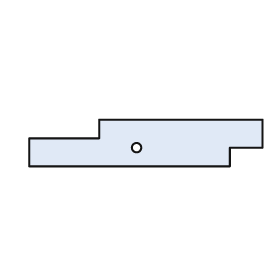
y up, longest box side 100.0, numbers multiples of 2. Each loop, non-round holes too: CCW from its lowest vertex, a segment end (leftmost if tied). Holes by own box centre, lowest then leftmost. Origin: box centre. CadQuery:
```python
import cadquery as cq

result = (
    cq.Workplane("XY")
    .moveTo(-50.0, -10.0)
    .lineTo(36.0, -10.0)
    .lineTo(36.0, -2.0)
    .lineTo(50.0, -2.0)
    .lineTo(50.0, 10.0)
    .lineTo(-20.0, 10.0)
    .lineTo(-20.0, 2.0)
    .lineTo(-50.0, 2.0)
    .close()
    .moveTo(-4.0, -2.0)
    .circle(2.0)
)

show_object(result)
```